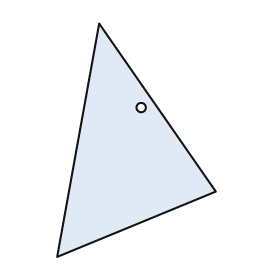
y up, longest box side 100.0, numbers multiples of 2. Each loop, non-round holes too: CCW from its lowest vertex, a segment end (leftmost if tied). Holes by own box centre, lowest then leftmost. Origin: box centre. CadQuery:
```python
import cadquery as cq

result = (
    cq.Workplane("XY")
    .moveTo(-34.0, -50.0)
    .lineTo(34.0, -22.0)
    .lineTo(-16.0, 50.0)
    .close()
    .moveTo(2.0, 14.0)
    .circle(2.0)
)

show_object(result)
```